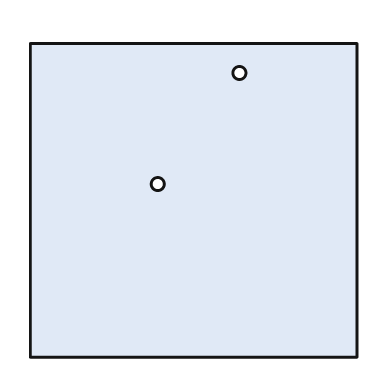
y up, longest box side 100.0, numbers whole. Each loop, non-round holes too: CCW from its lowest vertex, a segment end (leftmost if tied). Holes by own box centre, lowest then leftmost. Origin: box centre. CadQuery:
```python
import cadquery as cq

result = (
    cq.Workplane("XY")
    .moveTo(-50.0, -48.0)
    .lineTo(50.0, -48.0)
    .lineTo(50.0, 48.0)
    .lineTo(-50.0, 48.0)
    .close()
    .moveTo(-11.0, 5.0)
    .circle(2.0)
    .moveTo(14.0, 39.0)
    .circle(2.0)
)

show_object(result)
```